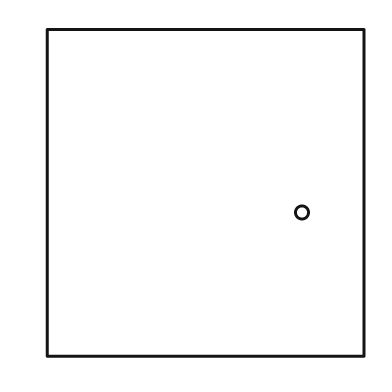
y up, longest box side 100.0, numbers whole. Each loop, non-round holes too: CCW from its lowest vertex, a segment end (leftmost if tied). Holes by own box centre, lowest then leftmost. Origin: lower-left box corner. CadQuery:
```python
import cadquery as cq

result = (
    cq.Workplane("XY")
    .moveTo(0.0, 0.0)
    .lineTo(97.0, 0.0)
    .lineTo(97.0, 100.0)
    .lineTo(0.0, 100.0)
    .close()
    .moveTo(78.0, 44.0)
    .circle(2.0)
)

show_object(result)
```